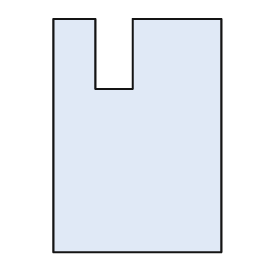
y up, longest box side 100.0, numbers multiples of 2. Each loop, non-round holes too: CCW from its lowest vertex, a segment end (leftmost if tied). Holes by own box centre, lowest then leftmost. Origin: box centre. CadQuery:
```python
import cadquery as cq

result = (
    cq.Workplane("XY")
    .moveTo(-36.0, -50.0)
    .lineTo(36.0, -50.0)
    .lineTo(36.0, 50.0)
    .lineTo(-2.0, 50.0)
    .lineTo(-2.0, 20.0)
    .lineTo(-18.0, 20.0)
    .lineTo(-18.0, 50.0)
    .lineTo(-36.0, 50.0)
    .close()
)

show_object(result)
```